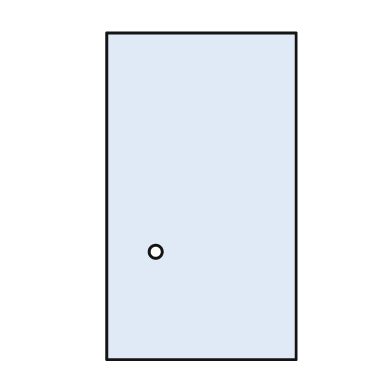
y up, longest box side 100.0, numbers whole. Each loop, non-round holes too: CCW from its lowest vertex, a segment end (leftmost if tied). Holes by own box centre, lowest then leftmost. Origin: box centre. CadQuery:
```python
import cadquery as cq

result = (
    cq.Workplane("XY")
    .moveTo(-29.0, -50.0)
    .lineTo(29.0, -50.0)
    .lineTo(29.0, 50.0)
    .lineTo(-29.0, 50.0)
    .close()
    .moveTo(-14.0, -17.0)
    .circle(2.0)
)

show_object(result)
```